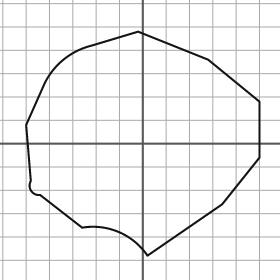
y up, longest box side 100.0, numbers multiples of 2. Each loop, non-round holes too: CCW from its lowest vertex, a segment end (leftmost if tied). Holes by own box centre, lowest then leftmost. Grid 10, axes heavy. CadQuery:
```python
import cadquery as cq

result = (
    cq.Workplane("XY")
    .moveTo(2.0, -48.0)
    .lineTo(34.0, -26.0)
    .lineTo(50.0, -6.0)
    .lineTo(50.0, 18.0)
    .lineTo(28.0, 36.0)
    .lineTo(-2.0, 48.0)
    .lineTo(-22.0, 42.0)
    .threePointArc((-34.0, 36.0), (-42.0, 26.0))
    .lineTo(-50.0, 8.0)
    .lineTo(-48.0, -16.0)
    .threePointArc((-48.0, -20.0), (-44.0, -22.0))
    .lineTo(-26.0, -36.0)
    .threePointArc((-10.0, -38.0), (2.0, -48.0))
    .close()
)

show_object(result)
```